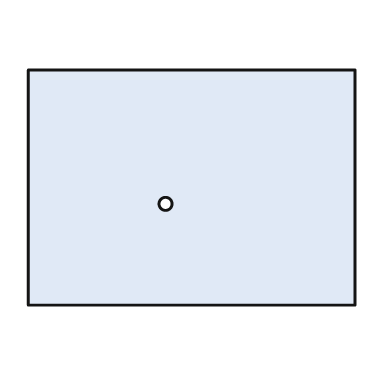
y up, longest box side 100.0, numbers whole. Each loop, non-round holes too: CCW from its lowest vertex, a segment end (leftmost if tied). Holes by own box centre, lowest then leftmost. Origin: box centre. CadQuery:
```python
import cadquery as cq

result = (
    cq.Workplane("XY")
    .moveTo(-50.0, -36.0)
    .lineTo(50.0, -36.0)
    .lineTo(50.0, 36.0)
    .lineTo(-50.0, 36.0)
    .close()
    .moveTo(-8.0, -5.0)
    .circle(2.0)
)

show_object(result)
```